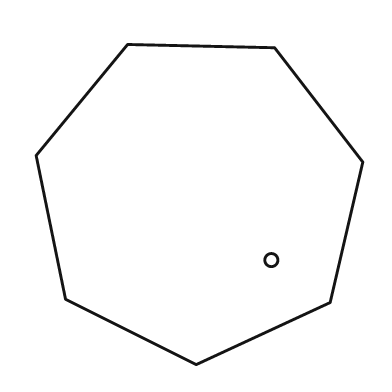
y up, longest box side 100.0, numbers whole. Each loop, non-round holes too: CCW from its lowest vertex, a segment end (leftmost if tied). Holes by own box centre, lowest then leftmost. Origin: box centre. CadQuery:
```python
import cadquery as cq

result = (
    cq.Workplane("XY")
    .moveTo(-1.0, -49.0)
    .lineTo(40.0, -30.0)
    .lineTo(50.0, 13.0)
    .lineTo(23.0, 48.0)
    .lineTo(-22.0, 49.0)
    .lineTo(-50.0, 15.0)
    .lineTo(-41.0, -29.0)
    .close()
    .moveTo(22.0, -17.0)
    .circle(2.0)
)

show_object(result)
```